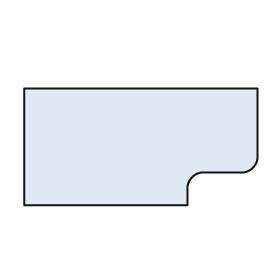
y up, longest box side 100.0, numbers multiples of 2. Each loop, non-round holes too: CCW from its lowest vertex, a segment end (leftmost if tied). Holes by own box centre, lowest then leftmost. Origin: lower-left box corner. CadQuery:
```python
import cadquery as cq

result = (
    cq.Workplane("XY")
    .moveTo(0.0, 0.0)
    .lineTo(70.0, 0.0)
    .lineTo(70.0, 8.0)
    .threePointArc((72.0, 12.0), (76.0, 14.0))
    .lineTo(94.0, 14.0)
    .threePointArc((98.0, 16.0), (100.0, 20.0))
    .lineTo(100.0, 50.0)
    .lineTo(0.0, 50.0)
    .close()
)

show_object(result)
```